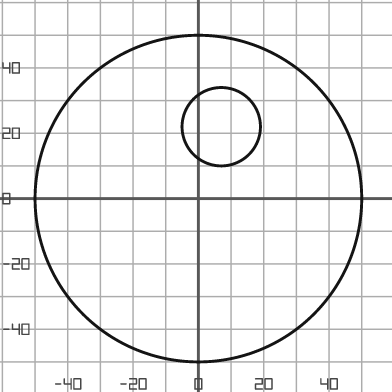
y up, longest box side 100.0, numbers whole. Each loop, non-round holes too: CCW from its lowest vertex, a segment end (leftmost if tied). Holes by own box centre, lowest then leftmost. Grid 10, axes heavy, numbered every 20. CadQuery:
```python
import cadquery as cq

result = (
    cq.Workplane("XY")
    .moveTo(0.0, 0.0)
    .circle(50.0)
    .moveTo(7.0, 22.0)
    .circle(12.0)
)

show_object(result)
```